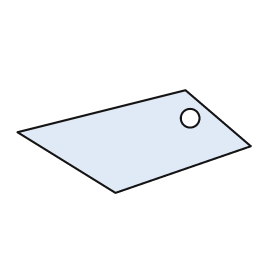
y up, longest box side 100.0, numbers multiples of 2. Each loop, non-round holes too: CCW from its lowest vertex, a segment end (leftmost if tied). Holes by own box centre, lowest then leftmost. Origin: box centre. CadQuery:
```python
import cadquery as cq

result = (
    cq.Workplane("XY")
    .moveTo(-8.0, -22.0)
    .lineTo(50.0, -2.0)
    .lineTo(22.0, 22.0)
    .lineTo(-50.0, 4.0)
    .close()
    .moveTo(24.0, 10.0)
    .circle(4.0)
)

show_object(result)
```